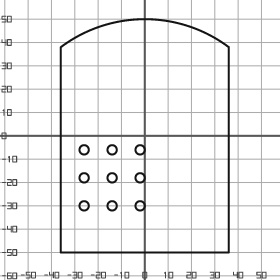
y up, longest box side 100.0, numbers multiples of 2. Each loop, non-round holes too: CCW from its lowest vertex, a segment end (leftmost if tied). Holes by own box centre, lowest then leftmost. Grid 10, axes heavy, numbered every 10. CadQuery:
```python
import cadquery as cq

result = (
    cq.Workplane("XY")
    .moveTo(-36.0, -50.0)
    .lineTo(36.0, -50.0)
    .lineTo(36.0, 38.0)
    .threePointArc((0.0, 50.0), (-36.0, 38.0))
    .close()
    .moveTo(-26.0, -30.0)
    .circle(2.0)
    .moveTo(-14.0, -30.0)
    .circle(2.0)
    .moveTo(-2.0, -30.0)
    .circle(2.0)
    .moveTo(-26.0, -18.0)
    .circle(2.0)
    .moveTo(-14.0, -18.0)
    .circle(2.0)
    .moveTo(-2.0, -18.0)
    .circle(2.0)
    .moveTo(-26.0, -6.0)
    .circle(2.0)
    .moveTo(-14.0, -6.0)
    .circle(2.0)
    .moveTo(-2.0, -6.0)
    .circle(2.0)
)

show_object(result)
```